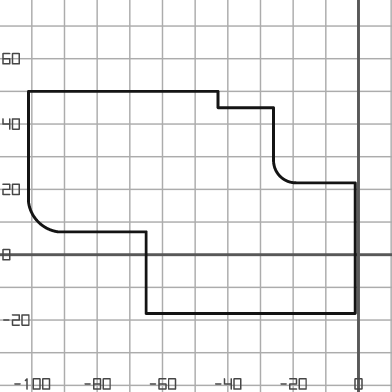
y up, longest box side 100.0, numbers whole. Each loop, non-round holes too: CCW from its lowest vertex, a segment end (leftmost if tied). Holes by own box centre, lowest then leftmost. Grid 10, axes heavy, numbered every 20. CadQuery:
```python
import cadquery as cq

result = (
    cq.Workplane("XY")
    .moveTo(-65.0, -18.0)
    .lineTo(-1.0, -18.0)
    .lineTo(-1.0, 22.0)
    .lineTo(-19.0, 22.0)
    .threePointArc((-24.0, 24.0), (-26.0, 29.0))
    .lineTo(-26.0, 45.0)
    .lineTo(-43.0, 45.0)
    .lineTo(-43.0, 50.0)
    .lineTo(-101.0, 50.0)
    .lineTo(-101.0, 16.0)
    .threePointArc((-98.0, 10.0), (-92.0, 7.0))
    .lineTo(-65.0, 7.0)
    .close()
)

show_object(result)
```